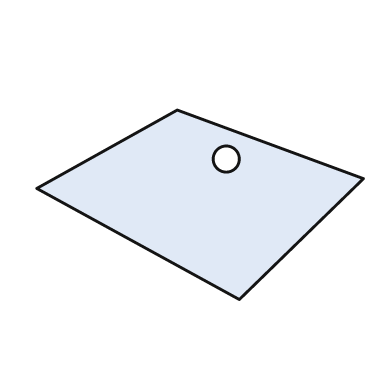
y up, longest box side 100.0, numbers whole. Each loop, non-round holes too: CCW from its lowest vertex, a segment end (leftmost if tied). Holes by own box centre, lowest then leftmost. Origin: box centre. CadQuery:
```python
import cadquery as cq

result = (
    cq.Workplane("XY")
    .moveTo(12.0, -29.0)
    .lineTo(50.0, 8.0)
    .lineTo(-7.0, 29.0)
    .lineTo(-50.0, 5.0)
    .close()
    .moveTo(8.0, 14.0)
    .circle(4.0)
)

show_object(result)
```